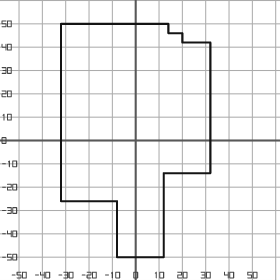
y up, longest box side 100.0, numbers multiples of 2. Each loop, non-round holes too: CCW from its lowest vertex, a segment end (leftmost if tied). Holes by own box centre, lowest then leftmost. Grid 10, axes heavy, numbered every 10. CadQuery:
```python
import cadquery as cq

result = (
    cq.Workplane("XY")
    .moveTo(-8.0, -50.0)
    .lineTo(12.0, -50.0)
    .lineTo(12.0, -14.0)
    .lineTo(32.0, -14.0)
    .lineTo(32.0, 42.0)
    .lineTo(20.0, 42.0)
    .lineTo(20.0, 46.0)
    .lineTo(14.0, 46.0)
    .lineTo(14.0, 50.0)
    .lineTo(-32.0, 50.0)
    .lineTo(-32.0, -26.0)
    .lineTo(-8.0, -26.0)
    .close()
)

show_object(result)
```